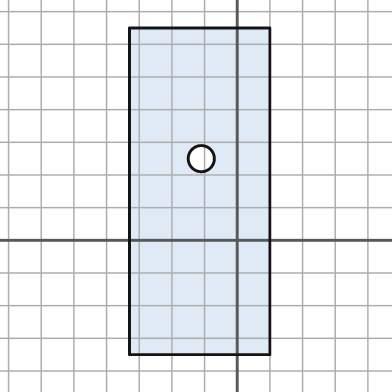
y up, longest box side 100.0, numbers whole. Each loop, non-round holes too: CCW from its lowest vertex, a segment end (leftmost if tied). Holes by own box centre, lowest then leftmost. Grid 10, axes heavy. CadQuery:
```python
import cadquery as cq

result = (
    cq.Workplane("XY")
    .moveTo(-33.0, -35.0)
    .lineTo(10.0, -35.0)
    .lineTo(10.0, 65.0)
    .lineTo(-33.0, 65.0)
    .close()
    .moveTo(-11.0, 25.0)
    .circle(4.0)
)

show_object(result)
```